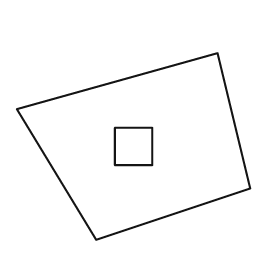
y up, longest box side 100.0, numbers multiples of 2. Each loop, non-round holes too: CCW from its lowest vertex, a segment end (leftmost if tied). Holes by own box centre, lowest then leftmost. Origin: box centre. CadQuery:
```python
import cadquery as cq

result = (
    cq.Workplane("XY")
    .moveTo(-16.0, -40.0)
    .lineTo(50.0, -18.0)
    .lineTo(36.0, 40.0)
    .lineTo(-50.0, 16.0)
    .close()
    .moveTo(-8.0, -8.0)
    .lineTo(8.0, -8.0)
    .lineTo(8.0, 8.0)
    .lineTo(-8.0, 8.0)
    .close()
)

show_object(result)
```